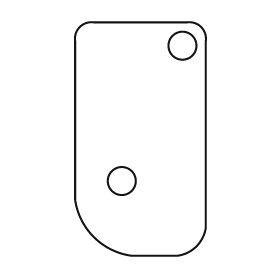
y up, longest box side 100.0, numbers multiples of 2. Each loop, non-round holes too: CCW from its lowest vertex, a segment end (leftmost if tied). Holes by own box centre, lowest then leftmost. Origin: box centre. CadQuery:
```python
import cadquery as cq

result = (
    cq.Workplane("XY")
    .moveTo(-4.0, -50.0)
    .lineTo(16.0, -50.0)
    .threePointArc((24.0, -46.0), (28.0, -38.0))
    .lineTo(28.0, 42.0)
    .threePointArc((26.0, 48.0), (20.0, 50.0))
    .lineTo(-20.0, 50.0)
    .threePointArc((-26.0, 48.0), (-28.0, 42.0))
    .lineTo(-28.0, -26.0)
    .threePointArc((-20.0, -42.0), (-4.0, -50.0))
    .close()
    .moveTo(-8.0, -18.0)
    .circle(6.0)
    .moveTo(18.0, 40.0)
    .circle(6.0)
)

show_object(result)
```